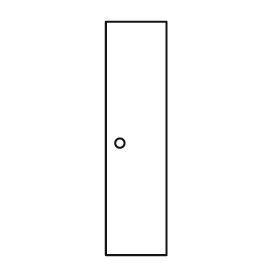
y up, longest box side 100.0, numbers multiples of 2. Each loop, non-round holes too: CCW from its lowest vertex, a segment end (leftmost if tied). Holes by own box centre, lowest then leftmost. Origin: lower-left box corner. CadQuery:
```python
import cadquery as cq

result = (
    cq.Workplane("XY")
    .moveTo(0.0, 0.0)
    .lineTo(26.0, 0.0)
    .lineTo(26.0, 100.0)
    .lineTo(0.0, 100.0)
    .close()
    .moveTo(6.0, 48.0)
    .circle(2.0)
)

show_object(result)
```